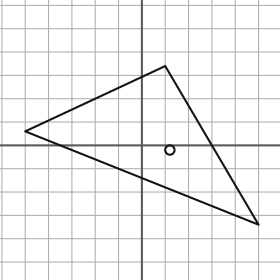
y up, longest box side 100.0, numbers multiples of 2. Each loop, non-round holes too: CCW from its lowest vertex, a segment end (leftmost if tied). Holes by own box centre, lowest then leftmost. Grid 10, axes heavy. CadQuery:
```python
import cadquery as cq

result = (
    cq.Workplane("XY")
    .moveTo(50.0, -34.0)
    .lineTo(10.0, 34.0)
    .lineTo(-50.0, 6.0)
    .close()
    .moveTo(12.0, -2.0)
    .circle(2.0)
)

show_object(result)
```